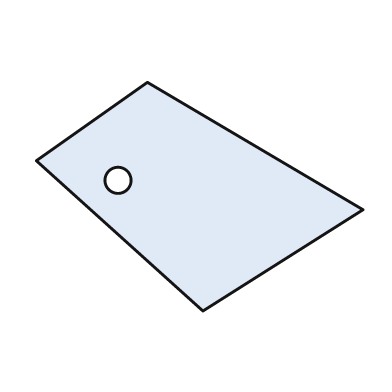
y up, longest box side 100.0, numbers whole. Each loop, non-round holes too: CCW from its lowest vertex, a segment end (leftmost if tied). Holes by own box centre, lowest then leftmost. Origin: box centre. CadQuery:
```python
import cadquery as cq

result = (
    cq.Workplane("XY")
    .moveTo(1.0, -35.0)
    .lineTo(50.0, -4.0)
    .lineTo(-16.0, 35.0)
    .lineTo(-50.0, 11.0)
    .close()
    .moveTo(-25.0, 5.0)
    .circle(4.0)
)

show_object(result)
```